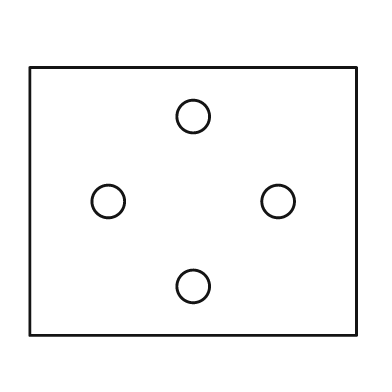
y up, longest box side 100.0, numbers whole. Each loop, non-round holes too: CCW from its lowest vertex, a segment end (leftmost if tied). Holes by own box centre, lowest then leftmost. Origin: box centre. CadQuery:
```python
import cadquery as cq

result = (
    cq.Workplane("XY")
    .moveTo(-50.0, -41.0)
    .lineTo(50.0, -41.0)
    .lineTo(50.0, 41.0)
    .lineTo(-50.0, 41.0)
    .close()
    .moveTo(0.0, -26.0)
    .circle(5.0)
    .moveTo(-26.0, 0.0)
    .circle(5.0)
    .moveTo(26.0, 0.0)
    .circle(5.0)
    .moveTo(0.0, 26.0)
    .circle(5.0)
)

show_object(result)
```